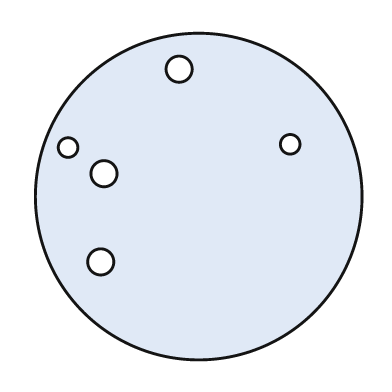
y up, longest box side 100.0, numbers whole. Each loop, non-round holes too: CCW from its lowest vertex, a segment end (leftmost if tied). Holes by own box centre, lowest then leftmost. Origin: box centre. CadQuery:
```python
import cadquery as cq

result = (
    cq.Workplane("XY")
    .moveTo(0.0, 0.0)
    .circle(50.0)
    .moveTo(-30.0, -20.0)
    .circle(4.0)
    .moveTo(-29.0, 7.0)
    .circle(4.0)
    .moveTo(-40.0, 15.0)
    .circle(3.0)
    .moveTo(28.0, 16.0)
    .circle(3.0)
    .moveTo(-6.0, 39.0)
    .circle(4.0)
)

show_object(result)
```